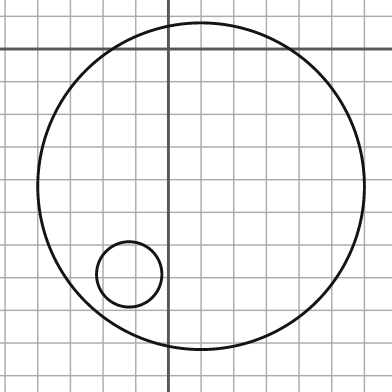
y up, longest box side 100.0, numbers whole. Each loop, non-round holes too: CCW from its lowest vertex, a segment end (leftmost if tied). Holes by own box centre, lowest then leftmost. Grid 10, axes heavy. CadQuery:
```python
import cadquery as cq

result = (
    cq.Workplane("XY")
    .moveTo(10.0, -42.0)
    .circle(50.0)
    .moveTo(-12.0, -69.0)
    .circle(10.0)
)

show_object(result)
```